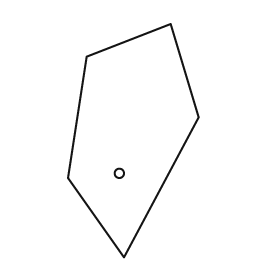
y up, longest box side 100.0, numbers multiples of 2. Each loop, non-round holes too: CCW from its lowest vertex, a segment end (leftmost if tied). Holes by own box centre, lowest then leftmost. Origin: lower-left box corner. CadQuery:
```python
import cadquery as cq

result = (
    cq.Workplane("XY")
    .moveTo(24.0, 0.0)
    .lineTo(56.0, 60.0)
    .lineTo(44.0, 100.0)
    .lineTo(8.0, 86.0)
    .lineTo(0.0, 34.0)
    .close()
    .moveTo(22.0, 36.0)
    .circle(2.0)
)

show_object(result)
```